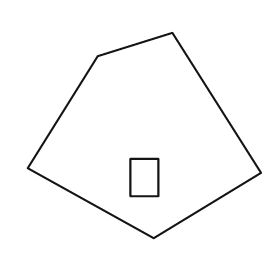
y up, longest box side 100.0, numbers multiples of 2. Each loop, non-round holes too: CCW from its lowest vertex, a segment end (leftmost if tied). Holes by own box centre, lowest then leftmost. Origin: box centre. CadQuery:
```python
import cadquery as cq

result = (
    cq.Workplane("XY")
    .moveTo(4.0, -44.0)
    .lineTo(50.0, -16.0)
    .lineTo(12.0, 44.0)
    .lineTo(-20.0, 34.0)
    .lineTo(-50.0, -14.0)
    .close()
    .moveTo(-6.0, -26.0)
    .lineTo(6.0, -26.0)
    .lineTo(6.0, -10.0)
    .lineTo(-6.0, -10.0)
    .close()
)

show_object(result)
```